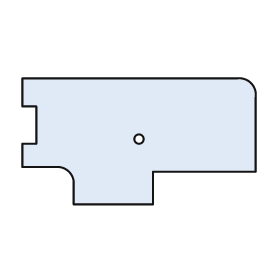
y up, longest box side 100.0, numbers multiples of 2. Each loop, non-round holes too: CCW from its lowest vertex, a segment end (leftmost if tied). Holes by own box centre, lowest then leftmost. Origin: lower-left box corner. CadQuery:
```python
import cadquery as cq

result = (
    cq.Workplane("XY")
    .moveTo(22.0, 0.0)
    .lineTo(56.0, 0.0)
    .lineTo(56.0, 14.0)
    .lineTo(100.0, 14.0)
    .lineTo(100.0, 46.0)
    .threePointArc((98.0, 52.0), (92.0, 54.0))
    .lineTo(0.0, 54.0)
    .lineTo(0.0, 42.0)
    .lineTo(6.0, 42.0)
    .lineTo(6.0, 26.0)
    .lineTo(0.0, 26.0)
    .lineTo(0.0, 16.0)
    .lineTo(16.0, 16.0)
    .threePointArc((20.0, 14.0), (22.0, 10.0))
    .close()
    .moveTo(50.0, 28.0)
    .circle(2.0)
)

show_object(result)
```